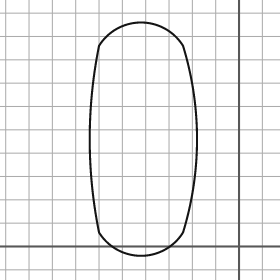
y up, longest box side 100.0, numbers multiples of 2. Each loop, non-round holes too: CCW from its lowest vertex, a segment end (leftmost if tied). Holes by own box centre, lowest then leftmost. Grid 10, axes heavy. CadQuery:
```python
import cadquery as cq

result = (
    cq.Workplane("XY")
    .moveTo(-60.0, 6.0)
    .threePointArc((-42.0, -4.0), (-24.0, 6.0))
    .threePointArc((-18.0, 46.0), (-24.0, 86.0))
    .threePointArc((-42.0, 96.0), (-60.0, 86.0))
    .threePointArc((-64.0, 46.0), (-60.0, 6.0))
    .close()
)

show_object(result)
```